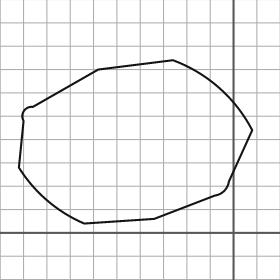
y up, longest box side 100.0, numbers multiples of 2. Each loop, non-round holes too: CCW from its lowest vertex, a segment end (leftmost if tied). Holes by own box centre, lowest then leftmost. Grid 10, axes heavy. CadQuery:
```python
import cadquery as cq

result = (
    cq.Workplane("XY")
    .moveTo(-64.0, 4.0)
    .lineTo(-34.0, 6.0)
    .lineTo(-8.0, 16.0)
    .threePointArc((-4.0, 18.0), (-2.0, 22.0))
    .lineTo(8.0, 44.0)
    .threePointArc((-6.0, 62.0), (-26.0, 74.0))
    .lineTo(-58.0, 70.0)
    .lineTo(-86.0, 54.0)
    .threePointArc((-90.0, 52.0), (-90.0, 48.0))
    .lineTo(-92.0, 28.0)
    .threePointArc((-80.0, 14.0), (-64.0, 4.0))
    .close()
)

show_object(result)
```